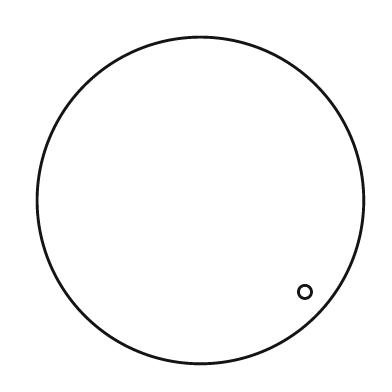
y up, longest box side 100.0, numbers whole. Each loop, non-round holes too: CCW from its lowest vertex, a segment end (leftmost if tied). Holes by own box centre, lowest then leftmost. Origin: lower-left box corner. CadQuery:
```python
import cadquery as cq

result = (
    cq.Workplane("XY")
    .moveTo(50.0, 50.0)
    .circle(50.0)
    .moveTo(82.0, 22.0)
    .circle(2.0)
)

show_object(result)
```